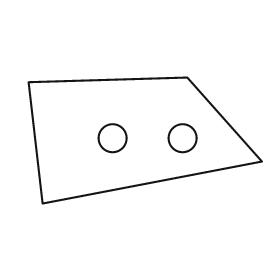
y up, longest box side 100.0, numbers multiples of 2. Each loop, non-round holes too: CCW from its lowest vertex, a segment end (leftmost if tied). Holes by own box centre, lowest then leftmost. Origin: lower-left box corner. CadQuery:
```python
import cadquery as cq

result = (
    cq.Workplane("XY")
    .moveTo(6.0, 0.0)
    .lineTo(100.0, 18.0)
    .lineTo(68.0, 54.0)
    .lineTo(0.0, 52.0)
    .close()
    .moveTo(36.0, 28.0)
    .circle(6.0)
    .moveTo(66.0, 28.0)
    .circle(6.0)
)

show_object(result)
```